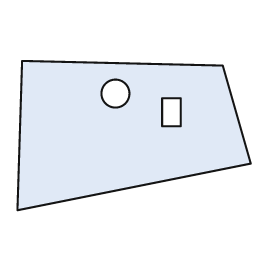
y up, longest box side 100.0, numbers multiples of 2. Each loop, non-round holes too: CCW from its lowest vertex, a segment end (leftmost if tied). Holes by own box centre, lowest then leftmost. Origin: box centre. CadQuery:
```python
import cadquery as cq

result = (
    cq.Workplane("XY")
    .moveTo(-50.0, -32.0)
    .lineTo(50.0, -12.0)
    .lineTo(38.0, 30.0)
    .lineTo(-48.0, 32.0)
    .close()
    .moveTo(12.0, 4.0)
    .lineTo(20.0, 4.0)
    .lineTo(20.0, 16.0)
    .lineTo(12.0, 16.0)
    .close()
    .moveTo(-8.0, 18.0)
    .circle(6.0)
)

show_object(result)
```